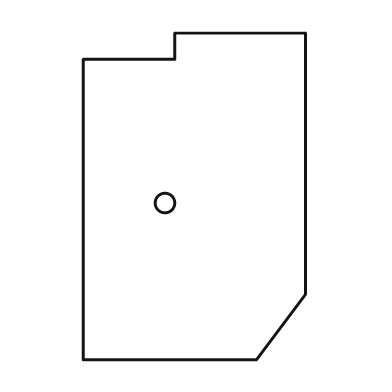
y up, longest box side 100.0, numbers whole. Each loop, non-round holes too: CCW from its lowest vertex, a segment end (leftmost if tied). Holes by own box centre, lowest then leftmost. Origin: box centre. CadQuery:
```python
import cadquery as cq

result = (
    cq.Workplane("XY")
    .moveTo(-34.0, -50.0)
    .lineTo(19.0, -50.0)
    .lineTo(34.0, -30.0)
    .lineTo(34.0, 50.0)
    .lineTo(-6.0, 50.0)
    .lineTo(-6.0, 42.0)
    .lineTo(-34.0, 42.0)
    .close()
    .moveTo(-9.0, -2.0)
    .circle(3.0)
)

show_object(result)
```